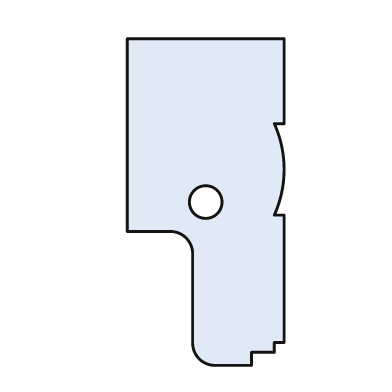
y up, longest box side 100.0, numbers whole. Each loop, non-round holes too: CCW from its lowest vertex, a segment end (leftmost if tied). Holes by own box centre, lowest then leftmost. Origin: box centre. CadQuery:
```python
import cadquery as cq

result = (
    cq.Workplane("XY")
    .moveTo(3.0, -50.0)
    .lineTo(14.0, -50.0)
    .lineTo(14.0, -46.0)
    .lineTo(21.0, -46.0)
    .lineTo(21.0, -43.0)
    .lineTo(24.0, -43.0)
    .lineTo(24.0, -4.0)
    .lineTo(21.0, -4.0)
    .threePointArc((24.0, 10.0), (21.0, 24.0))
    .lineTo(24.0, 24.0)
    .lineTo(24.0, 50.0)
    .lineTo(-24.0, 50.0)
    .lineTo(-24.0, -9.0)
    .lineTo(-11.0, -9.0)
    .threePointArc((-6.0, -11.0), (-4.0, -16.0))
    .lineTo(-4.0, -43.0)
    .threePointArc((-2.0, -48.0), (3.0, -50.0))
    .close()
    .moveTo(0.0, 0.0)
    .circle(5.0)
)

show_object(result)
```